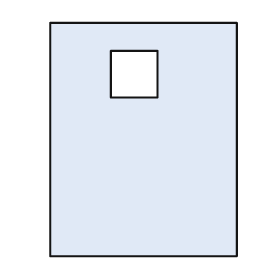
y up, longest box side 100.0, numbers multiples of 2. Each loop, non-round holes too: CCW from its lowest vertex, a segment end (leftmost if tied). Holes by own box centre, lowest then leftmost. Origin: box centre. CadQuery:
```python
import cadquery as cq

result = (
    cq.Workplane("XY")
    .moveTo(-40.0, -50.0)
    .lineTo(40.0, -50.0)
    .lineTo(40.0, 50.0)
    .lineTo(-40.0, 50.0)
    .close()
    .moveTo(-14.0, 18.0)
    .lineTo(6.0, 18.0)
    .lineTo(6.0, 38.0)
    .lineTo(-14.0, 38.0)
    .close()
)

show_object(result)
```